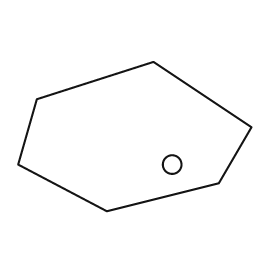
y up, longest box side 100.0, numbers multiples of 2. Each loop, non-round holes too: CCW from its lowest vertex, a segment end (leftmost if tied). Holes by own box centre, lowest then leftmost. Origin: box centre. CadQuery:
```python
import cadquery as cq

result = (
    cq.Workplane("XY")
    .moveTo(-12.0, -32.0)
    .lineTo(36.0, -20.0)
    .lineTo(50.0, 4.0)
    .lineTo(8.0, 32.0)
    .lineTo(-42.0, 16.0)
    .lineTo(-50.0, -12.0)
    .close()
    .moveTo(16.0, -12.0)
    .circle(4.0)
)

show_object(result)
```